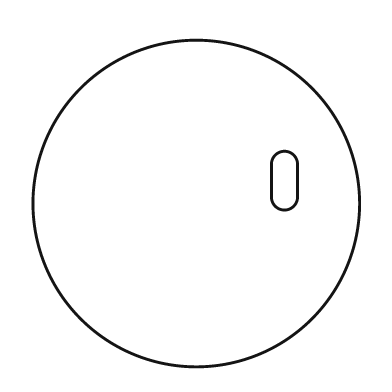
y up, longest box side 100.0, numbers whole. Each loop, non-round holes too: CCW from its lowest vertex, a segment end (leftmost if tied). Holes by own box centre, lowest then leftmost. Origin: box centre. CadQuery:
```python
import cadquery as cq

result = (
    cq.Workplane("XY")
    .moveTo(0.0, 0.0)
    .circle(50.0)
    .moveTo(23.0, 2.0)
    .threePointArc((27.0, -2.0), (31.0, 2.0))
    .lineTo(31.0, 12.0)
    .threePointArc((27.0, 16.0), (23.0, 12.0))
    .close()
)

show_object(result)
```